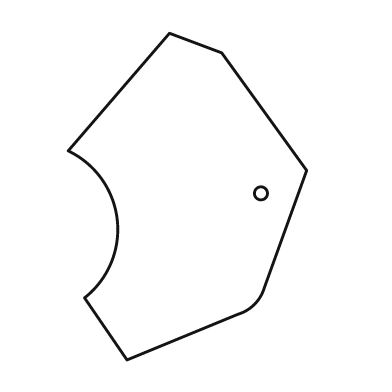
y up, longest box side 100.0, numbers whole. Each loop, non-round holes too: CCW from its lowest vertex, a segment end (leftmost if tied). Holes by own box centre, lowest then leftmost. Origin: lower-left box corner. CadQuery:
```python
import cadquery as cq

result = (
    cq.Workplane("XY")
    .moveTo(18.0, 0.0)
    .lineTo(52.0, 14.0)
    .threePointArc((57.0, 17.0), (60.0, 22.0))
    .lineTo(73.0, 58.0)
    .lineTo(47.0, 94.0)
    .lineTo(31.0, 100.0)
    .lineTo(0.0, 64.0)
    .threePointArc((15.0, 43.0), (5.0, 19.0))
    .close()
    .moveTo(59.0, 51.0)
    .circle(2.0)
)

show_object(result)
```